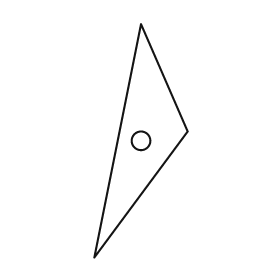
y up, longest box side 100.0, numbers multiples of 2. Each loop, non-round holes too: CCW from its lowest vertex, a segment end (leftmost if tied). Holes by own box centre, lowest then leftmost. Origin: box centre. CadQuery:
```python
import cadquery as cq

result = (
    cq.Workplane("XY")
    .moveTo(-20.0, -50.0)
    .lineTo(20.0, 4.0)
    .lineTo(0.0, 50.0)
    .close()
    .moveTo(0.0, 0.0)
    .circle(4.0)
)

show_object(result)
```